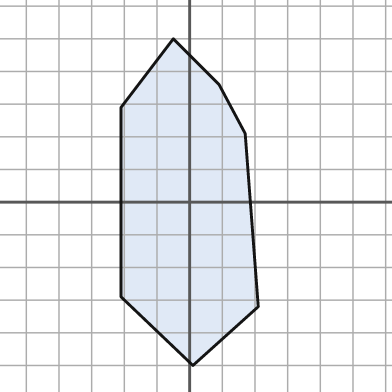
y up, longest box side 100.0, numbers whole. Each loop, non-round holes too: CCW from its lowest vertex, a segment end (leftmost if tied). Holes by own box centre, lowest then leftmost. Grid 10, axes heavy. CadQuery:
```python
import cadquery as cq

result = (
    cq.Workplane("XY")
    .moveTo(1.0, -50.0)
    .lineTo(21.0, -32.0)
    .lineTo(17.0, 21.0)
    .lineTo(9.0, 36.0)
    .lineTo(-5.0, 50.0)
    .lineTo(-21.0, 29.0)
    .lineTo(-21.0, -29.0)
    .close()
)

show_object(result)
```